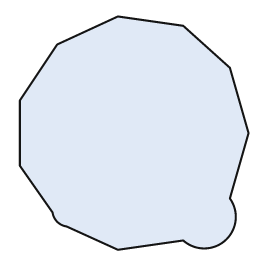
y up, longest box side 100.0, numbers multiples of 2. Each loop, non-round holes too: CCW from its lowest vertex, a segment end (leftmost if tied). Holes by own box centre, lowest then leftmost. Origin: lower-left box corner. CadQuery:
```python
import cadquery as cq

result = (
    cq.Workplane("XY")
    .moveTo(42.0, 0.0)
    .lineTo(70.0, 4.0)
    .threePointArc((88.0, 4.0), (90.0, 22.0))
    .lineTo(98.0, 50.0)
    .lineTo(90.0, 78.0)
    .lineTo(70.0, 96.0)
    .lineTo(42.0, 100.0)
    .lineTo(16.0, 88.0)
    .lineTo(0.0, 64.0)
    .lineTo(0.0, 36.0)
    .lineTo(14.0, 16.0)
    .threePointArc((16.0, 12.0), (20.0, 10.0))
    .close()
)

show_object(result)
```